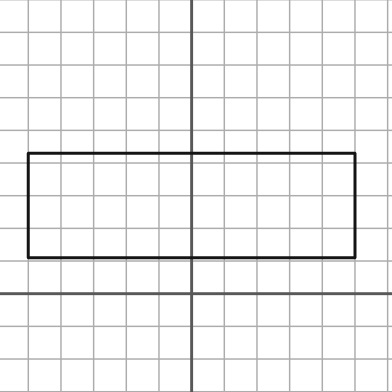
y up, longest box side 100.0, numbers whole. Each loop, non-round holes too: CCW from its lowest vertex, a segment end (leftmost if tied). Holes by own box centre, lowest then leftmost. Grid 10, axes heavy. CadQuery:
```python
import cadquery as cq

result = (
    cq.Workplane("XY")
    .moveTo(-50.0, 11.0)
    .lineTo(50.0, 11.0)
    .lineTo(50.0, 43.0)
    .lineTo(-50.0, 43.0)
    .close()
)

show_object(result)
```